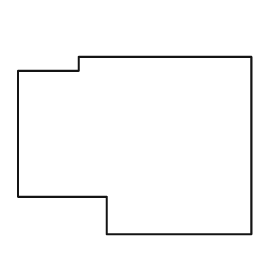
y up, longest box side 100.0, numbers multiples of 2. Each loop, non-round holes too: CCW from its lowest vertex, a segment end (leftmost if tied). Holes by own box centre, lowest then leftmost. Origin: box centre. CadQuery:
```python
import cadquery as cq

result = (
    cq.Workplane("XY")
    .moveTo(-12.0, -38.0)
    .lineTo(50.0, -38.0)
    .lineTo(50.0, 38.0)
    .lineTo(-24.0, 38.0)
    .lineTo(-24.0, 32.0)
    .lineTo(-50.0, 32.0)
    .lineTo(-50.0, -22.0)
    .lineTo(-12.0, -22.0)
    .close()
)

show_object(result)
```